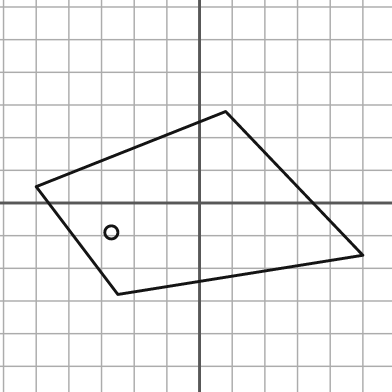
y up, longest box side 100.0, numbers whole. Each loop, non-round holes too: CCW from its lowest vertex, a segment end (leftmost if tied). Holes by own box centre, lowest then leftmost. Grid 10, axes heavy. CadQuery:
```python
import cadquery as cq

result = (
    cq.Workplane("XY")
    .moveTo(-25.0, -28.0)
    .lineTo(50.0, -16.0)
    .lineTo(8.0, 28.0)
    .lineTo(-50.0, 5.0)
    .close()
    .moveTo(-27.0, -9.0)
    .circle(2.0)
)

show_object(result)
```